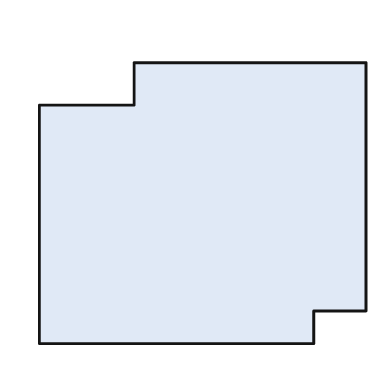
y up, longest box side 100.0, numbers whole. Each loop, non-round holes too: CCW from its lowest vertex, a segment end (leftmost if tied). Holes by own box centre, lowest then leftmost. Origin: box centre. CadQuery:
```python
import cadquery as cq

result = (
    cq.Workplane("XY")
    .moveTo(-50.0, -43.0)
    .lineTo(34.0, -43.0)
    .lineTo(34.0, -33.0)
    .lineTo(50.0, -33.0)
    .lineTo(50.0, 43.0)
    .lineTo(-21.0, 43.0)
    .lineTo(-21.0, 30.0)
    .lineTo(-50.0, 30.0)
    .close()
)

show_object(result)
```